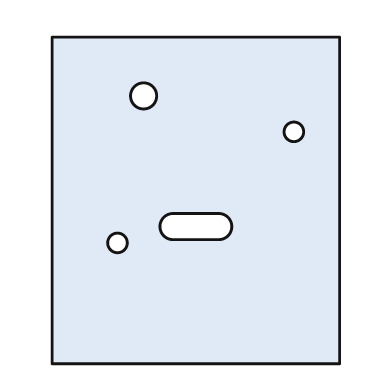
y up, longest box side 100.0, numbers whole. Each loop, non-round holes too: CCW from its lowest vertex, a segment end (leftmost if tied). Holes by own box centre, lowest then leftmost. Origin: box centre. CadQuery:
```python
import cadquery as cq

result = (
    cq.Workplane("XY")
    .moveTo(-44.0, -50.0)
    .lineTo(44.0, -50.0)
    .lineTo(44.0, 50.0)
    .lineTo(-44.0, 50.0)
    .close()
    .moveTo(-24.0, -13.0)
    .circle(3.0)
    .moveTo(-7.0, -12.0)
    .lineTo(7.0, -12.0)
    .threePointArc((11.0, -8.0), (7.0, -4.0))
    .lineTo(-7.0, -4.0)
    .threePointArc((-11.0, -8.0), (-7.0, -12.0))
    .close()
    .moveTo(30.0, 21.0)
    .circle(3.0)
    .moveTo(-16.0, 32.0)
    .circle(4.0)
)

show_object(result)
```